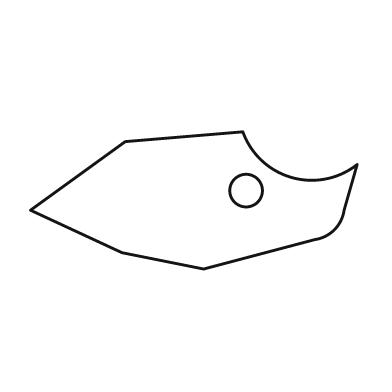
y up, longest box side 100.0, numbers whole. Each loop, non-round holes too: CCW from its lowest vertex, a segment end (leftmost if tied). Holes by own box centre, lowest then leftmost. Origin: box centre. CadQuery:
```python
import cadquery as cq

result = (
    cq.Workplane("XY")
    .moveTo(3.0, -21.0)
    .lineTo(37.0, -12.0)
    .threePointArc((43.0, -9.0), (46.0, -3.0))
    .lineTo(50.0, 11.0)
    .threePointArc((30.0, 7.0), (15.0, 21.0))
    .lineTo(-21.0, 18.0)
    .lineTo(-50.0, -3.0)
    .lineTo(-22.0, -16.0)
    .close()
    .moveTo(16.0, 3.0)
    .circle(5.0)
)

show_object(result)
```